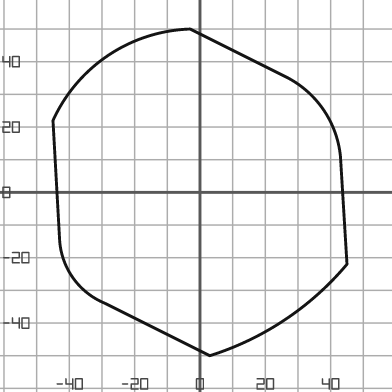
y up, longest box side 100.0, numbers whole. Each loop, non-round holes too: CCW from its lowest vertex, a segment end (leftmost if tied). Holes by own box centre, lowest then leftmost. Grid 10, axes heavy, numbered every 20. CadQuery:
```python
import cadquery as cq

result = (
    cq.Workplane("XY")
    .moveTo(3.0, -50.0)
    .threePointArc((26.0, -39.0), (45.0, -22.0))
    .lineTo(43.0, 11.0)
    .threePointArc((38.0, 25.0), (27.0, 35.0))
    .lineTo(-3.0, 50.0)
    .threePointArc((-28.0, 42.0), (-45.0, 22.0))
    .lineTo(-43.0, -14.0)
    .threePointArc((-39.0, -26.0), (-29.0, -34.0))
    .close()
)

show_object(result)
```